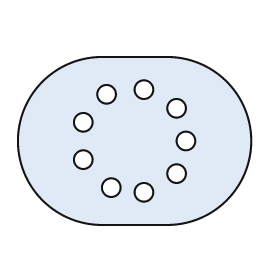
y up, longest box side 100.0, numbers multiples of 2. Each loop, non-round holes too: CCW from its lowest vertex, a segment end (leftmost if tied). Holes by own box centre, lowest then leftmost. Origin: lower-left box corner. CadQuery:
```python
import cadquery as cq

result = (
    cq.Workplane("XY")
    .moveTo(36.0, 0.0)
    .lineTo(64.0, 0.0)
    .threePointArc((100.0, 36.0), (64.0, 72.0))
    .lineTo(36.0, 72.0)
    .threePointArc((0.0, 36.0), (36.0, 0.0))
    .close()
    .moveTo(54.0, 14.0)
    .circle(4.0)
    .moveTo(40.0, 16.0)
    .circle(4.0)
    .moveTo(68.0, 22.0)
    .circle(4.0)
    .moveTo(28.0, 28.0)
    .circle(4.0)
    .moveTo(72.0, 36.0)
    .circle(4.0)
    .moveTo(28.0, 44.0)
    .circle(4.0)
    .moveTo(68.0, 50.0)
    .circle(4.0)
    .moveTo(38.0, 56.0)
    .circle(4.0)
    .moveTo(54.0, 58.0)
    .circle(4.0)
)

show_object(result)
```